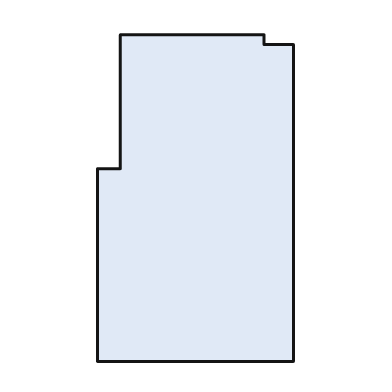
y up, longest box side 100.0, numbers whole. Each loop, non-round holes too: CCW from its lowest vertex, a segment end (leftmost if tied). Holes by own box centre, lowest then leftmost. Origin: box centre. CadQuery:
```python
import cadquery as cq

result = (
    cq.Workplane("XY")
    .moveTo(-30.0, -50.0)
    .lineTo(30.0, -50.0)
    .lineTo(30.0, 47.0)
    .lineTo(21.0, 47.0)
    .lineTo(21.0, 50.0)
    .lineTo(-23.0, 50.0)
    .lineTo(-23.0, 9.0)
    .lineTo(-30.0, 9.0)
    .close()
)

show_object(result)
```